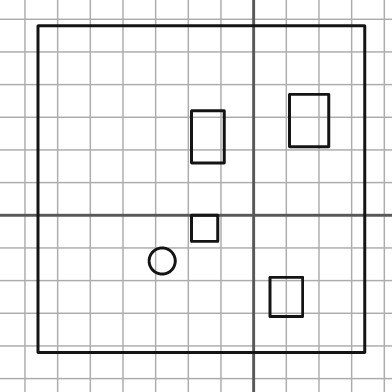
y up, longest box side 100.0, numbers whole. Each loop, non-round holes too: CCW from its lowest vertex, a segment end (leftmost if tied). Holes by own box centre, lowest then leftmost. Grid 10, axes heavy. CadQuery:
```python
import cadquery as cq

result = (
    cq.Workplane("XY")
    .moveTo(-66.0, -42.0)
    .lineTo(34.0, -42.0)
    .lineTo(34.0, 58.0)
    .lineTo(-66.0, 58.0)
    .close()
    .moveTo(5.0, -31.0)
    .lineTo(15.0, -31.0)
    .lineTo(15.0, -19.0)
    .lineTo(5.0, -19.0)
    .close()
    .moveTo(-28.0, -14.0)
    .circle(4.0)
    .moveTo(-19.0, -8.0)
    .lineTo(-11.0, -8.0)
    .lineTo(-11.0, 0.0)
    .lineTo(-19.0, 0.0)
    .close()
    .moveTo(-19.0, 16.0)
    .lineTo(-9.0, 16.0)
    .lineTo(-9.0, 32.0)
    .lineTo(-19.0, 32.0)
    .close()
    .moveTo(11.0, 21.0)
    .lineTo(23.0, 21.0)
    .lineTo(23.0, 37.0)
    .lineTo(11.0, 37.0)
    .close()
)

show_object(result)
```